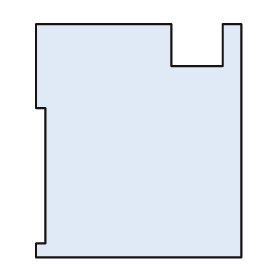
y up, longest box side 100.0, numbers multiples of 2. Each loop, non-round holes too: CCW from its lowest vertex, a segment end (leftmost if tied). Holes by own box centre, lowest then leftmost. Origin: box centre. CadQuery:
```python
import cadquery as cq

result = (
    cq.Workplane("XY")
    .moveTo(-44.0, -50.0)
    .lineTo(44.0, -50.0)
    .lineTo(44.0, 50.0)
    .lineTo(36.0, 50.0)
    .lineTo(36.0, 32.0)
    .lineTo(14.0, 32.0)
    .lineTo(14.0, 50.0)
    .lineTo(-44.0, 50.0)
    .lineTo(-44.0, 14.0)
    .lineTo(-40.0, 14.0)
    .lineTo(-40.0, -44.0)
    .lineTo(-44.0, -44.0)
    .close()
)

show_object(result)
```